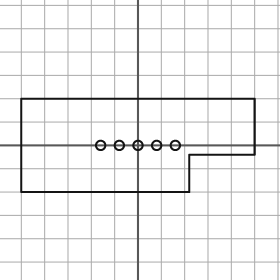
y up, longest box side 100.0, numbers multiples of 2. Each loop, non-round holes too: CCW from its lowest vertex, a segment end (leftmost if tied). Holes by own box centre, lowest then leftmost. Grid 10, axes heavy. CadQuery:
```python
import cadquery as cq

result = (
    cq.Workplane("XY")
    .moveTo(-50.0, -20.0)
    .lineTo(22.0, -20.0)
    .lineTo(22.0, -4.0)
    .lineTo(50.0, -4.0)
    .lineTo(50.0, 20.0)
    .lineTo(-50.0, 20.0)
    .close()
    .moveTo(-16.0, 0.0)
    .circle(2.0)
    .moveTo(-8.0, 0.0)
    .circle(2.0)
    .moveTo(0.0, 0.0)
    .circle(2.0)
    .moveTo(8.0, 0.0)
    .circle(2.0)
    .moveTo(16.0, 0.0)
    .circle(2.0)
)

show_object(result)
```